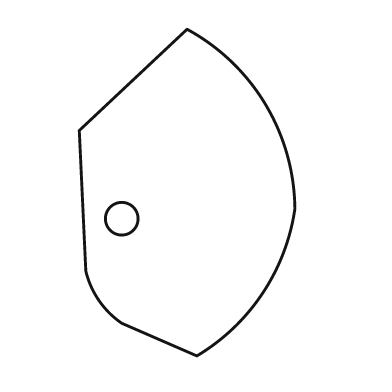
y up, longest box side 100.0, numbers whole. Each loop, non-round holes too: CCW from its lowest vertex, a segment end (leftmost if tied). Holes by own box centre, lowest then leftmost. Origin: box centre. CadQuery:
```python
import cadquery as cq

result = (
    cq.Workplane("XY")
    .moveTo(3.0, -50.0)
    .threePointArc((23.0, -31.0), (33.0, -5.0))
    .threePointArc((24.0, 27.0), (0.0, 50.0))
    .lineTo(-33.0, 19.0)
    .lineTo(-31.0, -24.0)
    .threePointArc((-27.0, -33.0), (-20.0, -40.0))
    .close()
    .moveTo(-20.0, -8.0)
    .circle(5.0)
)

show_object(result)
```